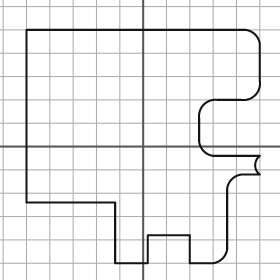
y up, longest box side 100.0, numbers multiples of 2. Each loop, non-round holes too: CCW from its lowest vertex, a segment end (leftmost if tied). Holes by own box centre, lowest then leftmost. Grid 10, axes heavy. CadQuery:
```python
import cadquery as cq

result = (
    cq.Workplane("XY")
    .moveTo(-12.0, -50.0)
    .lineTo(2.0, -50.0)
    .lineTo(2.0, -38.0)
    .lineTo(20.0, -38.0)
    .lineTo(20.0, -50.0)
    .lineTo(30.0, -50.0)
    .threePointArc((34.0, -48.0), (36.0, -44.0))
    .lineTo(36.0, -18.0)
    .threePointArc((38.0, -14.0), (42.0, -12.0))
    .lineTo(50.0, -12.0)
    .threePointArc((48.0, -8.0), (50.0, -4.0))
    .lineTo(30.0, -4.0)
    .threePointArc((26.0, -2.0), (24.0, 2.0))
    .lineTo(24.0, 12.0)
    .threePointArc((26.0, 18.0), (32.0, 20.0))
    .lineTo(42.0, 20.0)
    .threePointArc((48.0, 22.0), (50.0, 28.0))
    .lineTo(50.0, 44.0)
    .threePointArc((48.0, 48.0), (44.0, 50.0))
    .lineTo(-50.0, 50.0)
    .lineTo(-50.0, -24.0)
    .lineTo(-12.0, -24.0)
    .close()
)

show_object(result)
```